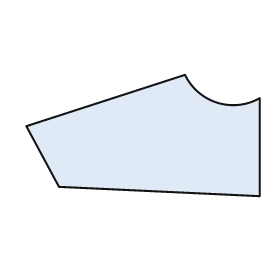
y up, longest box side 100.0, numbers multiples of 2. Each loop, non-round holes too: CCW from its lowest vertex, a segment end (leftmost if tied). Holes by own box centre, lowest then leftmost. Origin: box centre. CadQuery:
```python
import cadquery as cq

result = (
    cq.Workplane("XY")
    .moveTo(50.0, -26.0)
    .lineTo(50.0, 16.0)
    .threePointArc((32.0, 14.0), (18.0, 26.0))
    .lineTo(-50.0, 4.0)
    .lineTo(-36.0, -22.0)
    .close()
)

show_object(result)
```